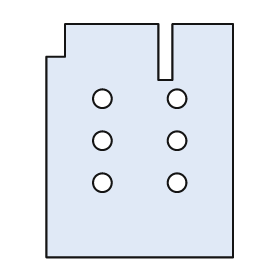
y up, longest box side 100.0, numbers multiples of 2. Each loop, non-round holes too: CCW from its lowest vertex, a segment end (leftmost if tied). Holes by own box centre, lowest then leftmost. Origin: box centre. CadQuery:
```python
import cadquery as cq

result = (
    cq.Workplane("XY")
    .moveTo(-40.0, -50.0)
    .lineTo(40.0, -50.0)
    .lineTo(40.0, 50.0)
    .lineTo(14.0, 50.0)
    .lineTo(14.0, 26.0)
    .lineTo(8.0, 26.0)
    .lineTo(8.0, 50.0)
    .lineTo(-32.0, 50.0)
    .lineTo(-32.0, 36.0)
    .lineTo(-40.0, 36.0)
    .close()
    .moveTo(-16.0, -18.0)
    .circle(4.0)
    .moveTo(16.0, -18.0)
    .circle(4.0)
    .moveTo(-16.0, 0.0)
    .circle(4.0)
    .moveTo(16.0, 0.0)
    .circle(4.0)
    .moveTo(-16.0, 18.0)
    .circle(4.0)
    .moveTo(16.0, 18.0)
    .circle(4.0)
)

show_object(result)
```